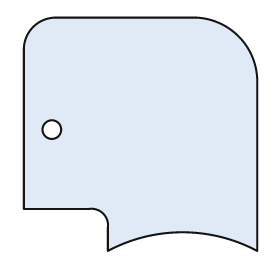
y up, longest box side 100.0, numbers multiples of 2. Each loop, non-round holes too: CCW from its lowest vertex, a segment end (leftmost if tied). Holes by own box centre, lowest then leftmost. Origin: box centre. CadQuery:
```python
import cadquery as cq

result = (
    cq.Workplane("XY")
    .moveTo(-14.0, -50.0)
    .threePointArc((18.0, -42.0), (50.0, -50.0))
    .lineTo(50.0, 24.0)
    .threePointArc((42.0, 42.0), (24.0, 50.0))
    .lineTo(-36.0, 50.0)
    .threePointArc((-46.0, 46.0), (-50.0, 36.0))
    .lineTo(-50.0, -32.0)
    .lineTo(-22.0, -32.0)
    .threePointArc((-16.0, -34.0), (-14.0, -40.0))
    .close()
    .moveTo(-38.0, 2.0)
    .circle(4.0)
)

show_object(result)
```